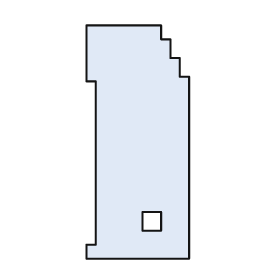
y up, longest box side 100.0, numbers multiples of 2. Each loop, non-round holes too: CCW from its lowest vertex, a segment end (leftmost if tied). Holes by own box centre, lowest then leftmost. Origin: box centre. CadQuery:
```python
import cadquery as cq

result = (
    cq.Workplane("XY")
    .moveTo(-22.0, -50.0)
    .lineTo(22.0, -50.0)
    .lineTo(22.0, 28.0)
    .lineTo(18.0, 28.0)
    .lineTo(18.0, 36.0)
    .lineTo(14.0, 36.0)
    .lineTo(14.0, 44.0)
    .lineTo(10.0, 44.0)
    .lineTo(10.0, 50.0)
    .lineTo(-22.0, 50.0)
    .lineTo(-22.0, 26.0)
    .lineTo(-18.0, 26.0)
    .lineTo(-18.0, -44.0)
    .lineTo(-22.0, -44.0)
    .close()
    .moveTo(2.0, -38.0)
    .lineTo(10.0, -38.0)
    .lineTo(10.0, -30.0)
    .lineTo(2.0, -30.0)
    .close()
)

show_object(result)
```